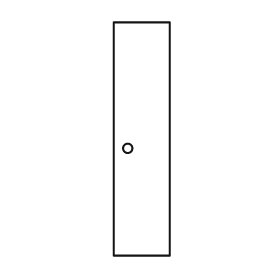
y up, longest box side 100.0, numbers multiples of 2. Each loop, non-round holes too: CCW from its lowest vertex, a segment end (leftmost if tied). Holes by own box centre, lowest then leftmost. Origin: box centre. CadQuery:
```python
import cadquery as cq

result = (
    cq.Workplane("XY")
    .moveTo(-12.0, -50.0)
    .lineTo(12.0, -50.0)
    .lineTo(12.0, 50.0)
    .lineTo(-12.0, 50.0)
    .close()
    .moveTo(-6.0, -4.0)
    .circle(2.0)
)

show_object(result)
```